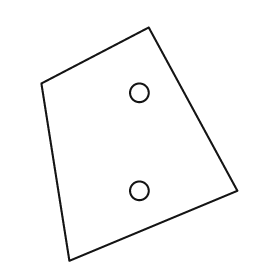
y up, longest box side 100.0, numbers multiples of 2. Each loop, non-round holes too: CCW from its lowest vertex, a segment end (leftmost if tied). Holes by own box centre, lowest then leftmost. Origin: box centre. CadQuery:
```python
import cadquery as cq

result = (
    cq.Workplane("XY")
    .moveTo(-30.0, -50.0)
    .lineTo(42.0, -20.0)
    .lineTo(4.0, 50.0)
    .lineTo(-42.0, 26.0)
    .close()
    .moveTo(0.0, -20.0)
    .circle(4.0)
    .moveTo(0.0, 22.0)
    .circle(4.0)
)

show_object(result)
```